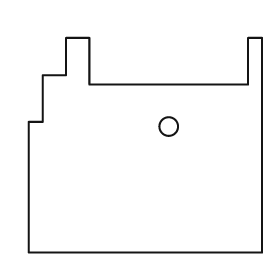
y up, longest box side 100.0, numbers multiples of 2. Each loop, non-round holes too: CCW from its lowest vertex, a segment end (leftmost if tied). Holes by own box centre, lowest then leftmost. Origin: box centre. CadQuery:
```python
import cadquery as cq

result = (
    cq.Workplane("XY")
    .moveTo(-50.0, -46.0)
    .lineTo(50.0, -46.0)
    .lineTo(50.0, 46.0)
    .lineTo(44.0, 46.0)
    .lineTo(44.0, 26.0)
    .lineTo(-24.0, 26.0)
    .lineTo(-24.0, 46.0)
    .lineTo(-34.0, 46.0)
    .lineTo(-34.0, 30.0)
    .lineTo(-44.0, 30.0)
    .lineTo(-44.0, 10.0)
    .lineTo(-50.0, 10.0)
    .close()
    .moveTo(10.0, 8.0)
    .circle(4.0)
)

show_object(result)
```